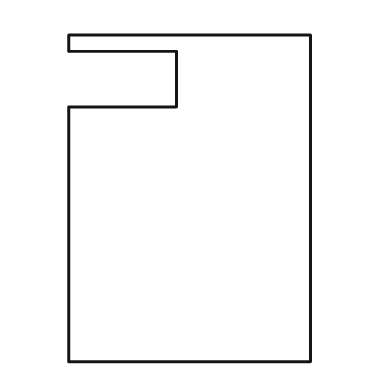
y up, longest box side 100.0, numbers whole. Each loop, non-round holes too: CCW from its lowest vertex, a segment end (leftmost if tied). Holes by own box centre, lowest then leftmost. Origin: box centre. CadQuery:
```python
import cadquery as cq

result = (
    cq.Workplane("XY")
    .moveTo(-37.0, -50.0)
    .lineTo(37.0, -50.0)
    .lineTo(37.0, 50.0)
    .lineTo(-37.0, 50.0)
    .lineTo(-37.0, 45.0)
    .lineTo(-4.0, 45.0)
    .lineTo(-4.0, 28.0)
    .lineTo(-37.0, 28.0)
    .close()
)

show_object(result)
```